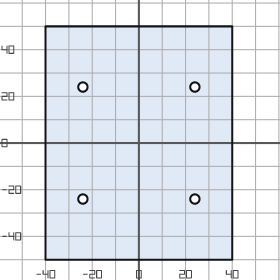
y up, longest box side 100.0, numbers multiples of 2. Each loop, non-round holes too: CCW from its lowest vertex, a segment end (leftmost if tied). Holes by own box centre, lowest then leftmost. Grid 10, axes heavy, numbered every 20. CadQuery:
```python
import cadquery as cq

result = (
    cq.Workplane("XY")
    .moveTo(-40.0, -50.0)
    .lineTo(40.0, -50.0)
    .lineTo(40.0, 50.0)
    .lineTo(-40.0, 50.0)
    .close()
    .moveTo(-24.0, -24.0)
    .circle(2.0)
    .moveTo(24.0, -24.0)
    .circle(2.0)
    .moveTo(-24.0, 24.0)
    .circle(2.0)
    .moveTo(24.0, 24.0)
    .circle(2.0)
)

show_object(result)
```